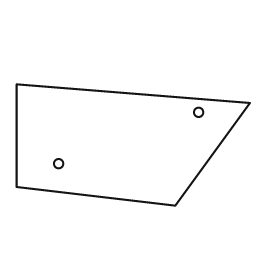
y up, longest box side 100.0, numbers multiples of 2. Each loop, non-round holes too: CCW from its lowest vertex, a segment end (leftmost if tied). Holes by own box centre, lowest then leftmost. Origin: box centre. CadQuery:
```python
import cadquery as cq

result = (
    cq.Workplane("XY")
    .moveTo(18.0, -26.0)
    .lineTo(50.0, 18.0)
    .lineTo(-50.0, 26.0)
    .lineTo(-50.0, -18.0)
    .close()
    .moveTo(-32.0, -8.0)
    .circle(2.0)
    .moveTo(28.0, 14.0)
    .circle(2.0)
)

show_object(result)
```